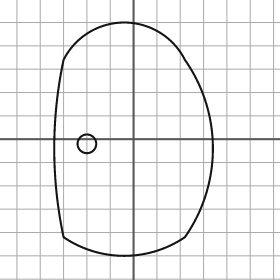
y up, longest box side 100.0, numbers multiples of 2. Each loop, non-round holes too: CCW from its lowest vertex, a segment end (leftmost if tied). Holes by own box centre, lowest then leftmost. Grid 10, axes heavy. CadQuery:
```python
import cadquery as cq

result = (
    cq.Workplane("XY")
    .moveTo(-30.0, -42.0)
    .threePointArc((-4.0, -50.0), (22.0, -42.0))
    .threePointArc((34.0, -4.0), (22.0, 34.0))
    .threePointArc((-4.0, 50.0), (-30.0, 34.0))
    .threePointArc((-34.0, -4.0), (-30.0, -42.0))
    .close()
    .moveTo(-20.0, -2.0)
    .circle(4.0)
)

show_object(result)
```